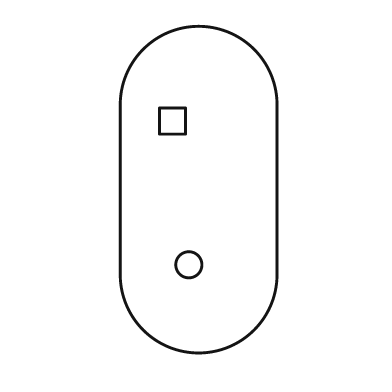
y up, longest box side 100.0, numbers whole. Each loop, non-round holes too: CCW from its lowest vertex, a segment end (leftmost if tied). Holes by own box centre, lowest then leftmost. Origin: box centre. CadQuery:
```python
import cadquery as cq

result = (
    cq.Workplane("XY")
    .moveTo(-24.0, -26.0)
    .threePointArc((0.0, -50.0), (24.0, -26.0))
    .lineTo(24.0, 26.0)
    .threePointArc((0.0, 50.0), (-24.0, 26.0))
    .close()
    .moveTo(-3.0, -23.0)
    .circle(4.0)
    .moveTo(-12.0, 17.0)
    .lineTo(-4.0, 17.0)
    .lineTo(-4.0, 25.0)
    .lineTo(-12.0, 25.0)
    .close()
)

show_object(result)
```